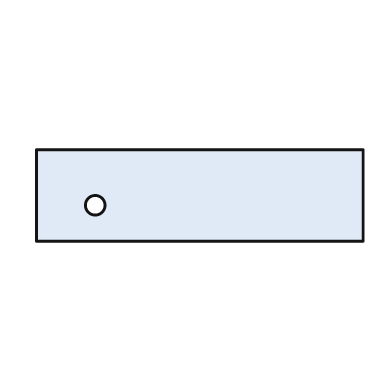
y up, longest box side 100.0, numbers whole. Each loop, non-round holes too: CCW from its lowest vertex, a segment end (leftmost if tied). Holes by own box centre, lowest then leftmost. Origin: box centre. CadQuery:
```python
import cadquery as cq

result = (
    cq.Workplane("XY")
    .moveTo(-50.0, -14.0)
    .lineTo(50.0, -14.0)
    .lineTo(50.0, 14.0)
    .lineTo(-50.0, 14.0)
    .close()
    .moveTo(-32.0, -3.0)
    .circle(3.0)
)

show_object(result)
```